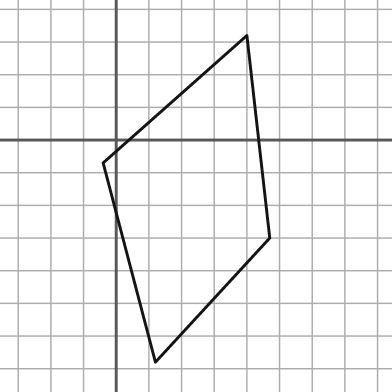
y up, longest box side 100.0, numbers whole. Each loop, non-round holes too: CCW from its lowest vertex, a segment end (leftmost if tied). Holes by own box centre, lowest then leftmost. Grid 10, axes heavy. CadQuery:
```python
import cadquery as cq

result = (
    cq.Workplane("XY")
    .moveTo(12.0, -68.0)
    .lineTo(47.0, -30.0)
    .lineTo(40.0, 32.0)
    .lineTo(-4.0, -7.0)
    .close()
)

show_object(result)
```